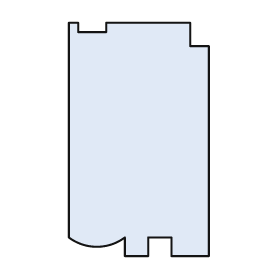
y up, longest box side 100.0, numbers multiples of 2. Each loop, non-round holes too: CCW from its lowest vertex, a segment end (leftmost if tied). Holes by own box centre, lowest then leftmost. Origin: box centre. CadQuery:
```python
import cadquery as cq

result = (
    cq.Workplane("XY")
    .moveTo(-6.0, -50.0)
    .lineTo(4.0, -50.0)
    .lineTo(4.0, -42.0)
    .lineTo(14.0, -42.0)
    .lineTo(14.0, -50.0)
    .lineTo(30.0, -50.0)
    .lineTo(30.0, 40.0)
    .lineTo(22.0, 40.0)
    .lineTo(22.0, 50.0)
    .lineTo(-14.0, 50.0)
    .lineTo(-14.0, 46.0)
    .lineTo(-26.0, 46.0)
    .lineTo(-26.0, 50.0)
    .lineTo(-30.0, 50.0)
    .lineTo(-30.0, -42.0)
    .threePointArc((-18.0, -46.0), (-6.0, -42.0))
    .close()
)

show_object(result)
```